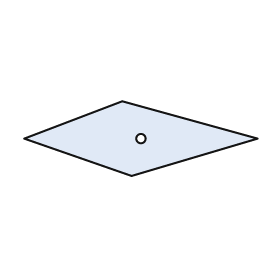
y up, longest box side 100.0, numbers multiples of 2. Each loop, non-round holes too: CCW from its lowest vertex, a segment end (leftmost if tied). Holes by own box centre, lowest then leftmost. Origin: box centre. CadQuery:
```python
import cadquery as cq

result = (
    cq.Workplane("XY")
    .moveTo(-4.0, -16.0)
    .lineTo(50.0, 0.0)
    .lineTo(-8.0, 16.0)
    .lineTo(-50.0, 0.0)
    .close()
    .moveTo(0.0, 0.0)
    .circle(2.0)
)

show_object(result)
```